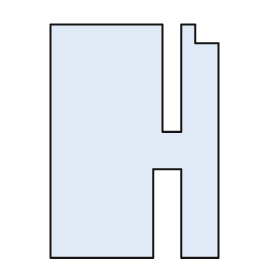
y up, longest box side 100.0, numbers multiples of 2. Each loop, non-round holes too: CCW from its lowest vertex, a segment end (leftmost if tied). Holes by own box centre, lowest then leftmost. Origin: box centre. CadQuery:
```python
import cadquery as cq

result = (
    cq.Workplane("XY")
    .moveTo(-36.0, -50.0)
    .lineTo(8.0, -50.0)
    .lineTo(8.0, -12.0)
    .lineTo(20.0, -12.0)
    .lineTo(20.0, -50.0)
    .lineTo(36.0, -50.0)
    .lineTo(36.0, 42.0)
    .lineTo(26.0, 42.0)
    .lineTo(26.0, 50.0)
    .lineTo(20.0, 50.0)
    .lineTo(20.0, 4.0)
    .lineTo(12.0, 4.0)
    .lineTo(12.0, 50.0)
    .lineTo(-36.0, 50.0)
    .close()
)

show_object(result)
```